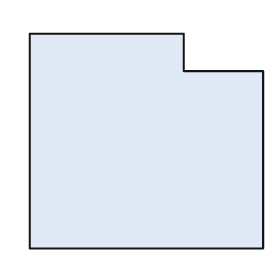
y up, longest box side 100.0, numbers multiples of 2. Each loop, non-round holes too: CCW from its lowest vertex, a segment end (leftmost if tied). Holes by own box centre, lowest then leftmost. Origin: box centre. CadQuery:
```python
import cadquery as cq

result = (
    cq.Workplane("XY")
    .moveTo(-50.0, -46.0)
    .lineTo(50.0, -46.0)
    .lineTo(50.0, 30.0)
    .lineTo(16.0, 30.0)
    .lineTo(16.0, 46.0)
    .lineTo(-50.0, 46.0)
    .close()
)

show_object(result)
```